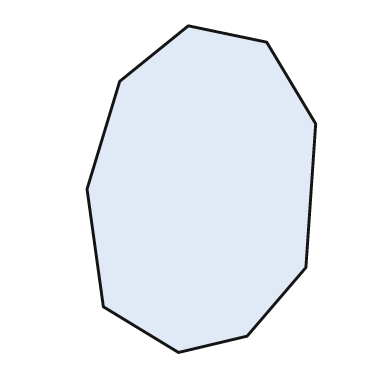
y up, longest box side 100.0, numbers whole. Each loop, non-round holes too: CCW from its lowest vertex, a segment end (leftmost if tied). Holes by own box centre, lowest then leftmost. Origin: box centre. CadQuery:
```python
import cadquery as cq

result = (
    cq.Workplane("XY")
    .moveTo(-7.0, -50.0)
    .lineTo(14.0, -45.0)
    .lineTo(32.0, -24.0)
    .lineTo(35.0, 20.0)
    .lineTo(20.0, 45.0)
    .lineTo(-4.0, 50.0)
    .lineTo(-25.0, 33.0)
    .lineTo(-35.0, 0.0)
    .lineTo(-30.0, -36.0)
    .close()
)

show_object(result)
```